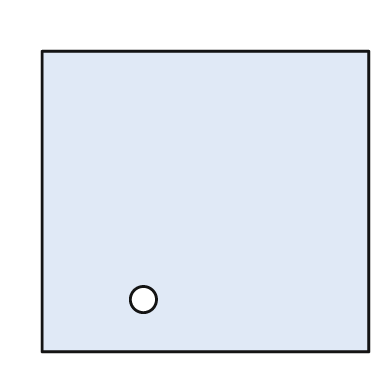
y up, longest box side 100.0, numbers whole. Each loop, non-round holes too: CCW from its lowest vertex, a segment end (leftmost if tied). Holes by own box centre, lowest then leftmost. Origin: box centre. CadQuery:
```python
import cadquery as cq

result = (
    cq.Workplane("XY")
    .moveTo(-50.0, -46.0)
    .lineTo(50.0, -46.0)
    .lineTo(50.0, 46.0)
    .lineTo(-50.0, 46.0)
    .close()
    .moveTo(-19.0, -30.0)
    .circle(4.0)
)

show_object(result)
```